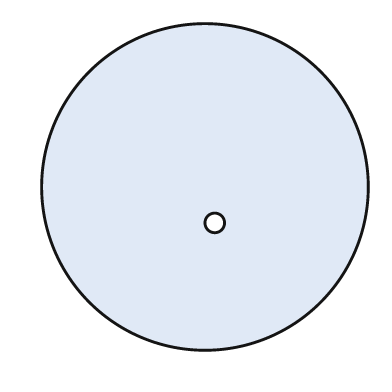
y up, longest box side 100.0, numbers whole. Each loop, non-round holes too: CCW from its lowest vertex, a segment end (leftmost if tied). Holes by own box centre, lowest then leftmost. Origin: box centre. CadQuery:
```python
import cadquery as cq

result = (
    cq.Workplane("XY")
    .moveTo(0.0, 0.0)
    .circle(50.0)
    .moveTo(3.0, -11.0)
    .circle(3.0)
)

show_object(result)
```